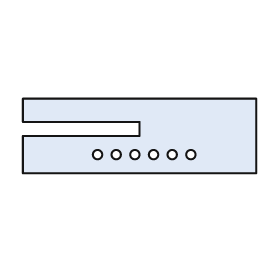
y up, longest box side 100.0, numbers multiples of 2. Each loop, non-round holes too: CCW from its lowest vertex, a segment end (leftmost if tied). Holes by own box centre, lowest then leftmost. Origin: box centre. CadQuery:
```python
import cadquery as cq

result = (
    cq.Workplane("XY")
    .moveTo(-50.0, -16.0)
    .lineTo(50.0, -16.0)
    .lineTo(50.0, 16.0)
    .lineTo(-50.0, 16.0)
    .lineTo(-50.0, 6.0)
    .lineTo(0.0, 6.0)
    .lineTo(0.0, 0.0)
    .lineTo(-50.0, 0.0)
    .close()
    .moveTo(-18.0, -8.0)
    .circle(2.0)
    .moveTo(-10.0, -8.0)
    .circle(2.0)
    .moveTo(-2.0, -8.0)
    .circle(2.0)
    .moveTo(6.0, -8.0)
    .circle(2.0)
    .moveTo(14.0, -8.0)
    .circle(2.0)
    .moveTo(22.0, -8.0)
    .circle(2.0)
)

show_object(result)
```